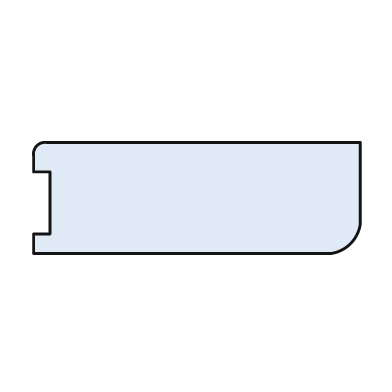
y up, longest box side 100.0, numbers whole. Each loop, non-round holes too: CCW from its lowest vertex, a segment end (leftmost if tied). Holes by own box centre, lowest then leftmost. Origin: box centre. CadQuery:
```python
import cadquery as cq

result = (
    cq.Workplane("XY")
    .moveTo(-50.0, -17.0)
    .lineTo(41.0, -17.0)
    .threePointArc((47.0, -14.0), (50.0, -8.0))
    .lineTo(50.0, 17.0)
    .lineTo(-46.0, 17.0)
    .threePointArc((-49.0, 16.0), (-50.0, 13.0))
    .lineTo(-50.0, 8.0)
    .lineTo(-45.0, 8.0)
    .lineTo(-45.0, -11.0)
    .lineTo(-50.0, -11.0)
    .close()
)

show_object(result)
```